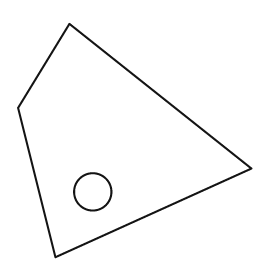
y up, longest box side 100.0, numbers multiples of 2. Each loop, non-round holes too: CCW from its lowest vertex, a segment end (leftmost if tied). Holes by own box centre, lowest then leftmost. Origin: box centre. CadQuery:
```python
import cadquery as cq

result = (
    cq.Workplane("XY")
    .moveTo(-34.0, -50.0)
    .lineTo(50.0, -12.0)
    .lineTo(-28.0, 50.0)
    .lineTo(-50.0, 14.0)
    .close()
    .moveTo(-18.0, -22.0)
    .circle(8.0)
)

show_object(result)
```